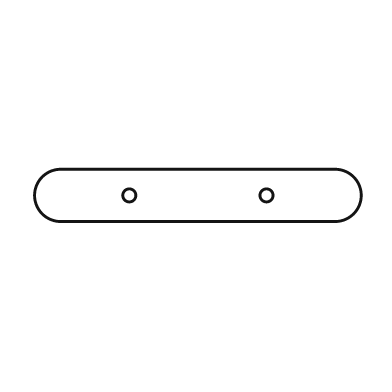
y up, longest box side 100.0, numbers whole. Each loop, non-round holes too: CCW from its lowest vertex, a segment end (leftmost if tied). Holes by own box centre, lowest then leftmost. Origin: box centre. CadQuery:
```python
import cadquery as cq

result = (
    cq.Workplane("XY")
    .moveTo(-42.0, -8.0)
    .lineTo(42.0, -8.0)
    .threePointArc((50.0, 0.0), (42.0, 8.0))
    .lineTo(-42.0, 8.0)
    .threePointArc((-50.0, 0.0), (-42.0, -8.0))
    .close()
    .moveTo(-21.0, 0.0)
    .circle(2.0)
    .moveTo(21.0, 0.0)
    .circle(2.0)
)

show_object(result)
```